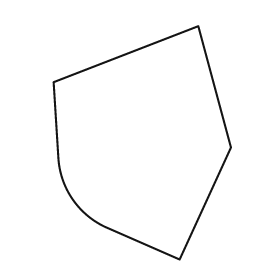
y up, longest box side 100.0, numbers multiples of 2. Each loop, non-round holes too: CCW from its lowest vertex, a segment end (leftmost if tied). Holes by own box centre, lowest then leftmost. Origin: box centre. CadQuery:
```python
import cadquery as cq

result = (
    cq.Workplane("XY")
    .moveTo(16.0, -50.0)
    .lineTo(38.0, -2.0)
    .lineTo(24.0, 50.0)
    .lineTo(-38.0, 26.0)
    .lineTo(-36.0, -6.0)
    .threePointArc((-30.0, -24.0), (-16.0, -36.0))
    .close()
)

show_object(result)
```